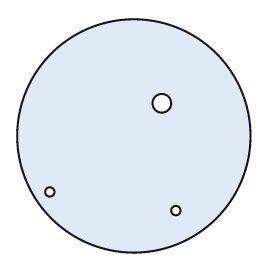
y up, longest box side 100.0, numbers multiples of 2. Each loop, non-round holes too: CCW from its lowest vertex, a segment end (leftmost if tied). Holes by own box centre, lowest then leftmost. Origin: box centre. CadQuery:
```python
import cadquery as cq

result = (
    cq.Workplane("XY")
    .moveTo(0.0, 0.0)
    .circle(50.0)
    .moveTo(18.0, -32.0)
    .circle(2.0)
    .moveTo(-36.0, -24.0)
    .circle(2.0)
    .moveTo(12.0, 14.0)
    .circle(4.0)
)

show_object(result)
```